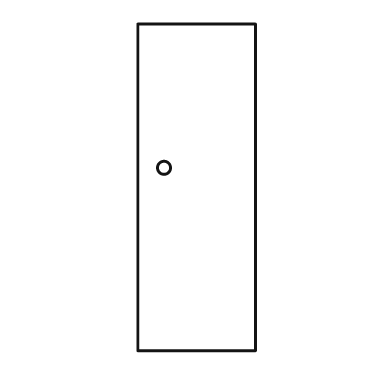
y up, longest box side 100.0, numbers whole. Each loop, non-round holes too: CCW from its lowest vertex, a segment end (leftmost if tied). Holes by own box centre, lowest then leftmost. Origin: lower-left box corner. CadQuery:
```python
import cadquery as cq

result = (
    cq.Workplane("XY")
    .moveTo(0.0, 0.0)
    .lineTo(36.0, 0.0)
    .lineTo(36.0, 100.0)
    .lineTo(0.0, 100.0)
    .close()
    .moveTo(8.0, 56.0)
    .circle(2.0)
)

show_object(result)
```